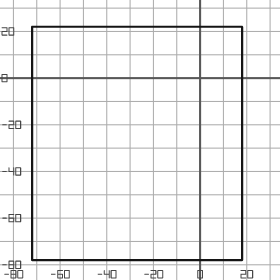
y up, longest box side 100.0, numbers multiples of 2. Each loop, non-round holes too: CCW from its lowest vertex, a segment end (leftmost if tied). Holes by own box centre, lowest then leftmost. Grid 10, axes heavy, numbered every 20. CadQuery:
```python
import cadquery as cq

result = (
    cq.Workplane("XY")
    .moveTo(-72.0, -78.0)
    .lineTo(18.0, -78.0)
    .lineTo(18.0, 22.0)
    .lineTo(-72.0, 22.0)
    .close()
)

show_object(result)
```